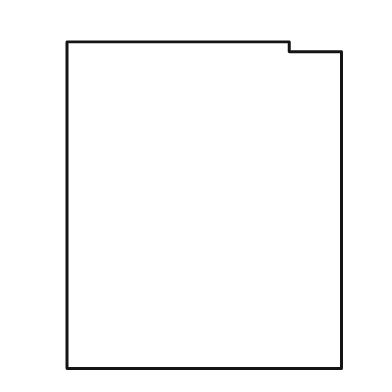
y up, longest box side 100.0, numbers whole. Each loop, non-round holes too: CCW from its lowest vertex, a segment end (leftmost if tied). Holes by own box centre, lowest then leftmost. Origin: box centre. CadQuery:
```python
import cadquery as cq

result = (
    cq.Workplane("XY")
    .moveTo(-42.0, -50.0)
    .lineTo(42.0, -50.0)
    .lineTo(42.0, 47.0)
    .lineTo(26.0, 47.0)
    .lineTo(26.0, 50.0)
    .lineTo(-42.0, 50.0)
    .close()
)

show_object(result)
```